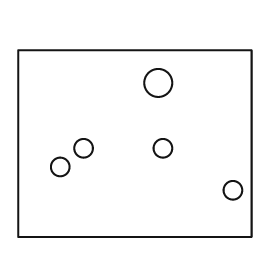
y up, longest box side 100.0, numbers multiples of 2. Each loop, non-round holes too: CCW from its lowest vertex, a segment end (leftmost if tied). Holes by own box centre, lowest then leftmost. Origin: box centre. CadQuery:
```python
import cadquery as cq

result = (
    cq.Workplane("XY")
    .moveTo(-50.0, -40.0)
    .lineTo(50.0, -40.0)
    .lineTo(50.0, 40.0)
    .lineTo(-50.0, 40.0)
    .close()
    .moveTo(42.0, -20.0)
    .circle(4.0)
    .moveTo(-32.0, -10.0)
    .circle(4.0)
    .moveTo(-22.0, -2.0)
    .circle(4.0)
    .moveTo(12.0, -2.0)
    .circle(4.0)
    .moveTo(10.0, 26.0)
    .circle(6.0)
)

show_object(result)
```